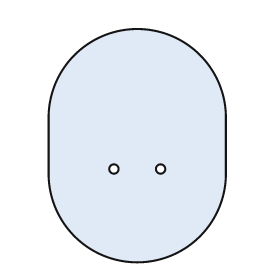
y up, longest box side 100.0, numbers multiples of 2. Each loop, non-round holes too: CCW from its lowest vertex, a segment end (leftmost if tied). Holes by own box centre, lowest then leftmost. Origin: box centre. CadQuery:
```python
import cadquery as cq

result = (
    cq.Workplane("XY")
    .moveTo(-38.0, -12.0)
    .threePointArc((0.0, -50.0), (38.0, -12.0))
    .lineTo(38.0, 12.0)
    .threePointArc((0.0, 50.0), (-38.0, 12.0))
    .close()
    .moveTo(-10.0, -10.0)
    .circle(2.0)
    .moveTo(10.0, -10.0)
    .circle(2.0)
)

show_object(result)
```